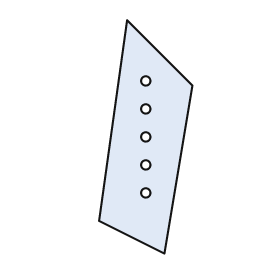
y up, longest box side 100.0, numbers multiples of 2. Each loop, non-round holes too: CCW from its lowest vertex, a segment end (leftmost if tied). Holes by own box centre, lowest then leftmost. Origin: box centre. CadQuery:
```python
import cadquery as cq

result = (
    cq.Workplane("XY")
    .moveTo(8.0, -50.0)
    .lineTo(20.0, 22.0)
    .lineTo(-8.0, 50.0)
    .lineTo(-20.0, -36.0)
    .close()
    .moveTo(0.0, -24.0)
    .circle(2.0)
    .moveTo(0.0, -12.0)
    .circle(2.0)
    .moveTo(0.0, 0.0)
    .circle(2.0)
    .moveTo(0.0, 12.0)
    .circle(2.0)
    .moveTo(0.0, 24.0)
    .circle(2.0)
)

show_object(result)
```